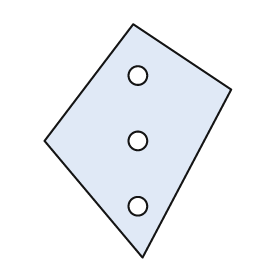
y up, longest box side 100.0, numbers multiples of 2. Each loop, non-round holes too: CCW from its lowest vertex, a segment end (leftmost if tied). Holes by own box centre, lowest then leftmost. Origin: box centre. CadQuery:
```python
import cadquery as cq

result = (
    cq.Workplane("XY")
    .moveTo(2.0, -50.0)
    .lineTo(40.0, 22.0)
    .lineTo(-2.0, 50.0)
    .lineTo(-40.0, 0.0)
    .close()
    .moveTo(0.0, -28.0)
    .circle(4.0)
    .moveTo(0.0, 0.0)
    .circle(4.0)
    .moveTo(0.0, 28.0)
    .circle(4.0)
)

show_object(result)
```